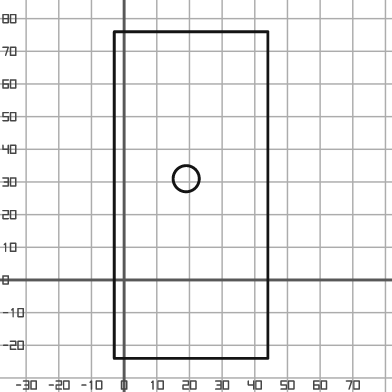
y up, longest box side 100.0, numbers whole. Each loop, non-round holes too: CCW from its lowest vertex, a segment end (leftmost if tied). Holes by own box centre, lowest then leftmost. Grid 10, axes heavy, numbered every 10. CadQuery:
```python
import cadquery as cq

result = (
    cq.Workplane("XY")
    .moveTo(-3.0, -24.0)
    .lineTo(44.0, -24.0)
    .lineTo(44.0, 76.0)
    .lineTo(-3.0, 76.0)
    .close()
    .moveTo(19.0, 31.0)
    .circle(4.0)
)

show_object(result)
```